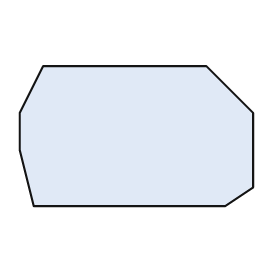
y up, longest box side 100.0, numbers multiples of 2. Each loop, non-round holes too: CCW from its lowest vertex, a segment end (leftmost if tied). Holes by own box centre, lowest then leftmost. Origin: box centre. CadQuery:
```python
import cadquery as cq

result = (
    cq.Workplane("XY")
    .moveTo(-44.0, -30.0)
    .lineTo(38.0, -30.0)
    .lineTo(50.0, -22.0)
    .lineTo(50.0, 10.0)
    .lineTo(30.0, 30.0)
    .lineTo(-40.0, 30.0)
    .lineTo(-50.0, 10.0)
    .lineTo(-50.0, -6.0)
    .close()
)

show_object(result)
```